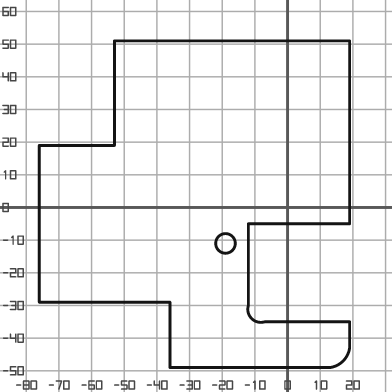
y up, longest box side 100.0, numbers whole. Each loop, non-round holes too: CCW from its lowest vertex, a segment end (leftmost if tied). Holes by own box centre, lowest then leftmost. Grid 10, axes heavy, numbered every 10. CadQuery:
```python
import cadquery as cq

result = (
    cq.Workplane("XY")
    .moveTo(-36.0, -49.0)
    .lineTo(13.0, -49.0)
    .threePointArc((17.0, -47.0), (19.0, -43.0))
    .lineTo(19.0, -35.0)
    .lineTo(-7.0, -35.0)
    .threePointArc((-11.0, -34.0), (-12.0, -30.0))
    .lineTo(-12.0, -5.0)
    .lineTo(19.0, -5.0)
    .lineTo(19.0, 51.0)
    .lineTo(-53.0, 51.0)
    .lineTo(-53.0, 19.0)
    .lineTo(-76.0, 19.0)
    .lineTo(-76.0, -29.0)
    .lineTo(-36.0, -29.0)
    .close()
    .moveTo(-19.0, -11.0)
    .circle(3.0)
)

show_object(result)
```